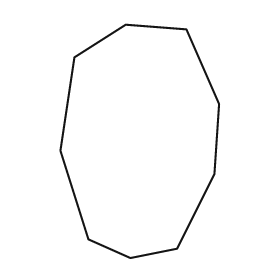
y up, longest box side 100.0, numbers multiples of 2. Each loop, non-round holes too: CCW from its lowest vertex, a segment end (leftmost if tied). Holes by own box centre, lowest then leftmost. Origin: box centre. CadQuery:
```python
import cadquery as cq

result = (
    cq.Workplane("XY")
    .moveTo(-4.0, -50.0)
    .lineTo(16.0, -46.0)
    .lineTo(32.0, -14.0)
    .lineTo(34.0, 16.0)
    .lineTo(20.0, 48.0)
    .lineTo(-6.0, 50.0)
    .lineTo(-28.0, 36.0)
    .lineTo(-34.0, -4.0)
    .lineTo(-22.0, -42.0)
    .close()
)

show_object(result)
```